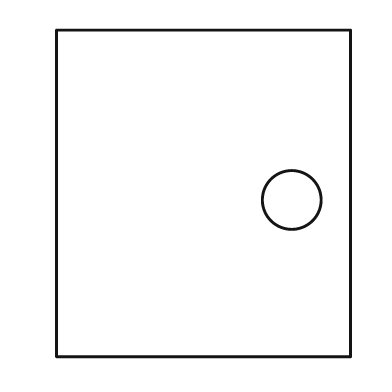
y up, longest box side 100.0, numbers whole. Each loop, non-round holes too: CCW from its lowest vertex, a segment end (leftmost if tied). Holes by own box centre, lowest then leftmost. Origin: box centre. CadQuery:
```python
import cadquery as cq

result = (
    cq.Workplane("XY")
    .moveTo(-45.0, -50.0)
    .lineTo(45.0, -50.0)
    .lineTo(45.0, 50.0)
    .lineTo(-45.0, 50.0)
    .close()
    .moveTo(27.0, -2.0)
    .circle(9.0)
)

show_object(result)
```